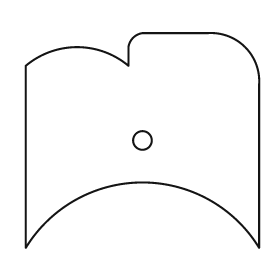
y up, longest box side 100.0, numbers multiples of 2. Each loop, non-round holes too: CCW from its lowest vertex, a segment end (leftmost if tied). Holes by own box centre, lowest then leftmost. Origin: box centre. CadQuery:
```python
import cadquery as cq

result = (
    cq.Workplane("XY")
    .moveTo(-50.0, -46.0)
    .threePointArc((0.0, -18.0), (50.0, -46.0))
    .lineTo(50.0, 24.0)
    .threePointArc((44.0, 40.0), (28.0, 46.0))
    .lineTo(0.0, 46.0)
    .threePointArc((-4.0, 44.0), (-6.0, 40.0))
    .lineTo(-6.0, 32.0)
    .threePointArc((-28.0, 40.0), (-50.0, 32.0))
    .close()
    .moveTo(0.0, 0.0)
    .circle(4.0)
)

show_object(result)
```